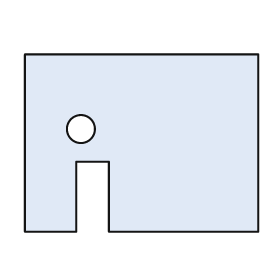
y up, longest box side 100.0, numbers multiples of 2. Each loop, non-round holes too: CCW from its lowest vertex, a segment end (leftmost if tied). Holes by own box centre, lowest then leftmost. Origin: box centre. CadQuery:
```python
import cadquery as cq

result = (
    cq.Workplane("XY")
    .moveTo(-50.0, -38.0)
    .lineTo(-28.0, -38.0)
    .lineTo(-28.0, -8.0)
    .lineTo(-14.0, -8.0)
    .lineTo(-14.0, -38.0)
    .lineTo(50.0, -38.0)
    .lineTo(50.0, 38.0)
    .lineTo(-50.0, 38.0)
    .close()
    .moveTo(-26.0, 6.0)
    .circle(6.0)
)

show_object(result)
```